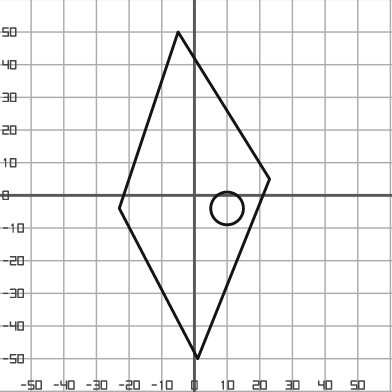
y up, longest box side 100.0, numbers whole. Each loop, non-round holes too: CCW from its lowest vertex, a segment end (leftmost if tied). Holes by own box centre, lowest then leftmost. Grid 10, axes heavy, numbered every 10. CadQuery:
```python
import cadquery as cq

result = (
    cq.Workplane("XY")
    .moveTo(1.0, -50.0)
    .lineTo(23.0, 5.0)
    .lineTo(-5.0, 50.0)
    .lineTo(-23.0, -4.0)
    .close()
    .moveTo(10.0, -4.0)
    .circle(5.0)
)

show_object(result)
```